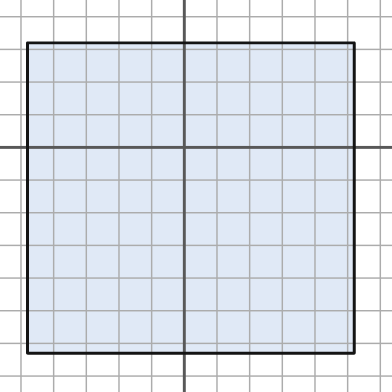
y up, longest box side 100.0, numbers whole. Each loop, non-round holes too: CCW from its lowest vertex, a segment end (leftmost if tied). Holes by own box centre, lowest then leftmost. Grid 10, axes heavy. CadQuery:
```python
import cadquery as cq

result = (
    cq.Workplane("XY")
    .moveTo(-48.0, -63.0)
    .lineTo(52.0, -63.0)
    .lineTo(52.0, 32.0)
    .lineTo(-48.0, 32.0)
    .close()
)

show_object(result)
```